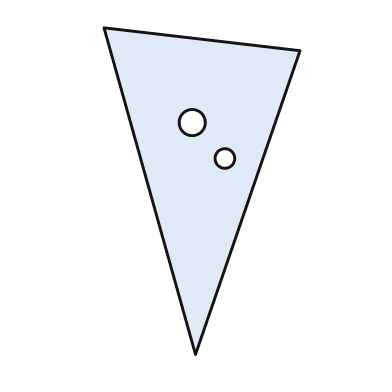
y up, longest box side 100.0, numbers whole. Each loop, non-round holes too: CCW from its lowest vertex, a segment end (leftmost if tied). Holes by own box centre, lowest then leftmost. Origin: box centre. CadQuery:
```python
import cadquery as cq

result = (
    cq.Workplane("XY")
    .moveTo(-2.0, -50.0)
    .lineTo(30.0, 43.0)
    .lineTo(-30.0, 50.0)
    .close()
    .moveTo(7.0, 10.0)
    .circle(3.0)
    .moveTo(-3.0, 21.0)
    .circle(4.0)
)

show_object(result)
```